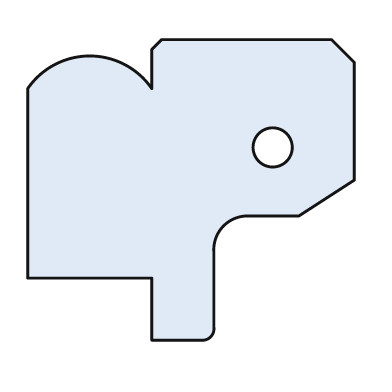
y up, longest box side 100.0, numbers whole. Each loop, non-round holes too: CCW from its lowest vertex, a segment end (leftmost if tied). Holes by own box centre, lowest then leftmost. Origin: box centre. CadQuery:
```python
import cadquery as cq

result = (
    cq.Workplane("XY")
    .moveTo(-12.0, -46.0)
    .lineTo(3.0, -46.0)
    .threePointArc((6.0, -45.0), (7.0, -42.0))
    .lineTo(7.0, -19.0)
    .threePointArc((10.0, -11.0), (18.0, -8.0))
    .lineTo(33.0, -8.0)
    .lineTo(50.0, 3.0)
    .lineTo(50.0, 39.0)
    .lineTo(43.0, 46.0)
    .lineTo(-9.0, 46.0)
    .lineTo(-12.0, 43.0)
    .lineTo(-12.0, 31.0)
    .threePointArc((-31.0, 41.0), (-50.0, 31.0))
    .lineTo(-50.0, -27.0)
    .lineTo(-12.0, -27.0)
    .close()
    .moveTo(25.0, 13.0)
    .circle(6.0)
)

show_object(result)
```